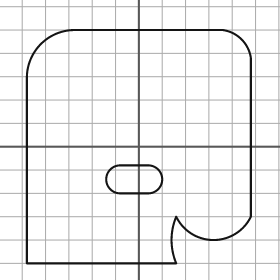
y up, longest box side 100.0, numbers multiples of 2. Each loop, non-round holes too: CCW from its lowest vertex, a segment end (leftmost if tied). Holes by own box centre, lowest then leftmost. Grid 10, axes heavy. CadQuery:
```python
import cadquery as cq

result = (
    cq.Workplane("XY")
    .moveTo(-48.0, -50.0)
    .lineTo(16.0, -50.0)
    .threePointArc((14.0, -40.0), (16.0, -30.0))
    .threePointArc((32.0, -40.0), (48.0, -30.0))
    .lineTo(48.0, 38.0)
    .threePointArc((44.0, 46.0), (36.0, 50.0))
    .lineTo(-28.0, 50.0)
    .threePointArc((-42.0, 44.0), (-48.0, 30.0))
    .close()
    .moveTo(-8.0, -20.0)
    .lineTo(4.0, -20.0)
    .threePointArc((10.0, -14.0), (4.0, -8.0))
    .lineTo(-8.0, -8.0)
    .threePointArc((-14.0, -14.0), (-8.0, -20.0))
    .close()
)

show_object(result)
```